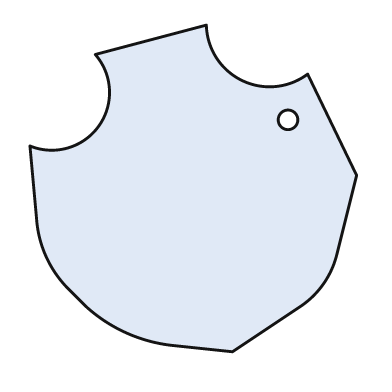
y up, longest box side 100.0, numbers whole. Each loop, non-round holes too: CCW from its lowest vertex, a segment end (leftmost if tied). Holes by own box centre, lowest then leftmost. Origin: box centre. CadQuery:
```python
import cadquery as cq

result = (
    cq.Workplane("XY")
    .moveTo(12.0, -50.0)
    .lineTo(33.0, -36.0)
    .threePointArc((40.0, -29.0), (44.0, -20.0))
    .lineTo(50.0, 4.0)
    .lineTo(35.0, 35.0)
    .threePointArc((15.0, 33.0), (4.0, 50.0))
    .lineTo(-30.0, 41.0)
    .threePointArc((-29.0, 19.0), (-50.0, 13.0))
    .lineTo(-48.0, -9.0)
    .threePointArc((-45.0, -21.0), (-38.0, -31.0))
    .lineTo(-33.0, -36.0)
    .threePointArc((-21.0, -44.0), (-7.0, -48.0))
    .close()
    .moveTo(29.0, 21.0)
    .circle(3.0)
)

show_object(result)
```